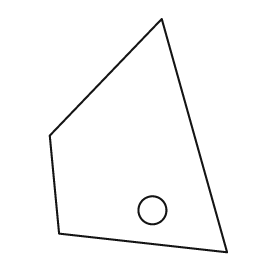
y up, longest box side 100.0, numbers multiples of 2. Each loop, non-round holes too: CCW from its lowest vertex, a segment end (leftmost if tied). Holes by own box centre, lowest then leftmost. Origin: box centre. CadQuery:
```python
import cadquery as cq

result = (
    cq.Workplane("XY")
    .moveTo(38.0, -50.0)
    .lineTo(10.0, 50.0)
    .lineTo(-38.0, 0.0)
    .lineTo(-34.0, -42.0)
    .close()
    .moveTo(6.0, -32.0)
    .circle(6.0)
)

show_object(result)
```